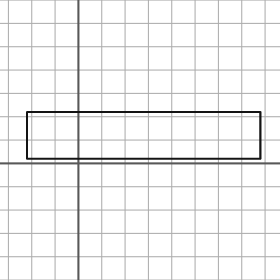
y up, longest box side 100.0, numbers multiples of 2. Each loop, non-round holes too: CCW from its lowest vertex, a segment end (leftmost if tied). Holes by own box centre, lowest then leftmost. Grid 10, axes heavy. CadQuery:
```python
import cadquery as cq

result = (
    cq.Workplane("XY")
    .moveTo(-22.0, 2.0)
    .lineTo(78.0, 2.0)
    .lineTo(78.0, 22.0)
    .lineTo(-22.0, 22.0)
    .close()
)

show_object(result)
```